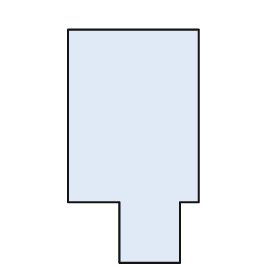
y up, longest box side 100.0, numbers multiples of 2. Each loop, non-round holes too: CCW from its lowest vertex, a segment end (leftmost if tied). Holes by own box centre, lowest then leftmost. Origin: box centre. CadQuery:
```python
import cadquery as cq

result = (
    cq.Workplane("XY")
    .moveTo(-6.0, -50.0)
    .lineTo(20.0, -50.0)
    .lineTo(20.0, -24.0)
    .lineTo(28.0, -24.0)
    .lineTo(28.0, 50.0)
    .lineTo(-28.0, 50.0)
    .lineTo(-28.0, -24.0)
    .lineTo(-6.0, -24.0)
    .close()
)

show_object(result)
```